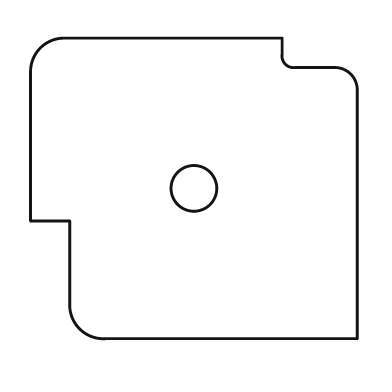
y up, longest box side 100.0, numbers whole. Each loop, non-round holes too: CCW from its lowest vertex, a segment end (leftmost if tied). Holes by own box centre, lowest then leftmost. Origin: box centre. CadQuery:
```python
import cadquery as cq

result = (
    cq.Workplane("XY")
    .moveTo(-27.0, -46.0)
    .lineTo(50.0, -46.0)
    .lineTo(50.0, 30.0)
    .threePointArc((48.0, 35.0), (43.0, 37.0))
    .lineTo(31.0, 37.0)
    .threePointArc((28.0, 38.0), (27.0, 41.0))
    .lineTo(27.0, 46.0)
    .lineTo(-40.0, 46.0)
    .threePointArc((-47.0, 43.0), (-50.0, 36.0))
    .lineTo(-50.0, -10.0)
    .lineTo(-38.0, -10.0)
    .lineTo(-38.0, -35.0)
    .threePointArc((-35.0, -43.0), (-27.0, -46.0))
    .close()
    .moveTo(0.0, 0.0)
    .circle(7.0)
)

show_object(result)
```